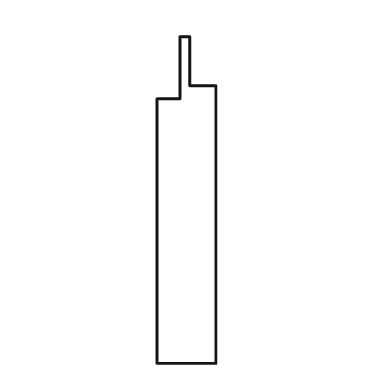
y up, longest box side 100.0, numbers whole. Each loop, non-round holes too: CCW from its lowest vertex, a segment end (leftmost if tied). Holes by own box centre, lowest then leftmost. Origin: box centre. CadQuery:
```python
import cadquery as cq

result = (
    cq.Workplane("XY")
    .moveTo(-9.0, -50.0)
    .lineTo(9.0, -50.0)
    .lineTo(9.0, 35.0)
    .lineTo(1.0, 35.0)
    .lineTo(1.0, 50.0)
    .lineTo(-2.0, 50.0)
    .lineTo(-2.0, 31.0)
    .lineTo(-9.0, 31.0)
    .close()
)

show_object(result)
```